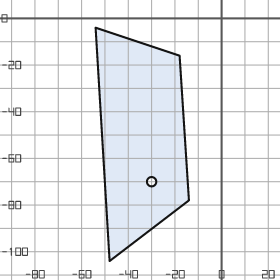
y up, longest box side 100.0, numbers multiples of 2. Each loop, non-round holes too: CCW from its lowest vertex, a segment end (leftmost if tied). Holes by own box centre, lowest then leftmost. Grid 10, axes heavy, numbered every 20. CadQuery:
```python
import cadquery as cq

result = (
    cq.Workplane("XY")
    .moveTo(-48.0, -104.0)
    .lineTo(-14.0, -78.0)
    .lineTo(-18.0, -16.0)
    .lineTo(-54.0, -4.0)
    .close()
    .moveTo(-30.0, -70.0)
    .circle(2.0)
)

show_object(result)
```